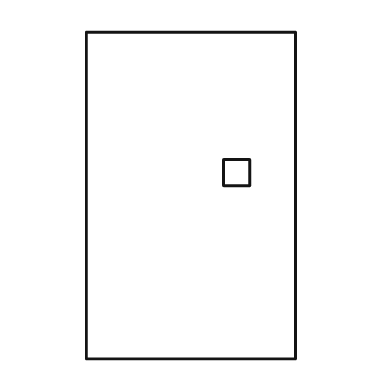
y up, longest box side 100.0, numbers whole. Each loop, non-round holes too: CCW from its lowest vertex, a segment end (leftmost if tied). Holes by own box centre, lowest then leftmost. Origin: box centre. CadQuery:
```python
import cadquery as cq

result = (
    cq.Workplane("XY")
    .moveTo(-32.0, -50.0)
    .lineTo(32.0, -50.0)
    .lineTo(32.0, 50.0)
    .lineTo(-32.0, 50.0)
    .close()
    .moveTo(10.0, 3.0)
    .lineTo(18.0, 3.0)
    .lineTo(18.0, 11.0)
    .lineTo(10.0, 11.0)
    .close()
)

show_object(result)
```